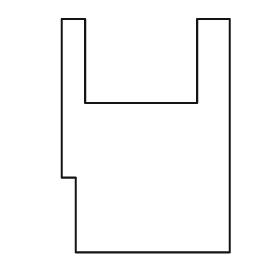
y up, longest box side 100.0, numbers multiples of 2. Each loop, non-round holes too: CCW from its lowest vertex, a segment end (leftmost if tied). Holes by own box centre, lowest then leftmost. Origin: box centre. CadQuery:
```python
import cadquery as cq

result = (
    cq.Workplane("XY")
    .moveTo(-30.0, -50.0)
    .lineTo(36.0, -50.0)
    .lineTo(36.0, 50.0)
    .lineTo(22.0, 50.0)
    .lineTo(22.0, 14.0)
    .lineTo(-26.0, 14.0)
    .lineTo(-26.0, 50.0)
    .lineTo(-36.0, 50.0)
    .lineTo(-36.0, -18.0)
    .lineTo(-30.0, -18.0)
    .close()
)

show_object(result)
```